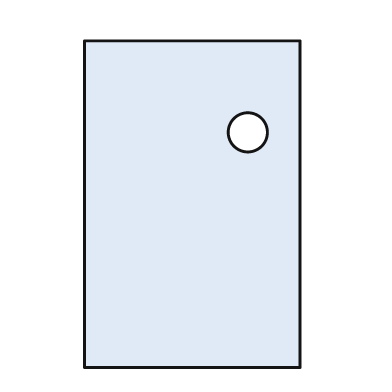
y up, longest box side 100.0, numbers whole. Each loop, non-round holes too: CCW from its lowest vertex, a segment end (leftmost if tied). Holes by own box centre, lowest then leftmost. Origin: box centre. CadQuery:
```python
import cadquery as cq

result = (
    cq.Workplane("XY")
    .moveTo(-33.0, -50.0)
    .lineTo(33.0, -50.0)
    .lineTo(33.0, 50.0)
    .lineTo(-33.0, 50.0)
    .close()
    .moveTo(17.0, 22.0)
    .circle(6.0)
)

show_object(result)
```